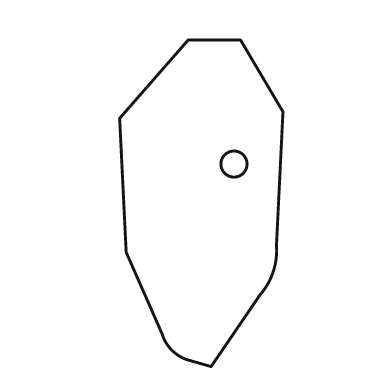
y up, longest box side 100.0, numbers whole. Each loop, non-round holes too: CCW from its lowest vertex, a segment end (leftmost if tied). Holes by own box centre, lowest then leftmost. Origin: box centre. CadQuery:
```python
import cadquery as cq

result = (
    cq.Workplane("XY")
    .moveTo(3.0, -50.0)
    .lineTo(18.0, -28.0)
    .threePointArc((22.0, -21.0), (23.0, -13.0))
    .lineTo(25.0, 28.0)
    .lineTo(12.0, 50.0)
    .lineTo(-4.0, 50.0)
    .lineTo(-25.0, 26.0)
    .lineTo(-23.0, -15.0)
    .lineTo(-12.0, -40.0)
    .threePointArc((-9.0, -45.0), (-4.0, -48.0))
    .close()
    .moveTo(10.0, 12.0)
    .circle(4.0)
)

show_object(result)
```